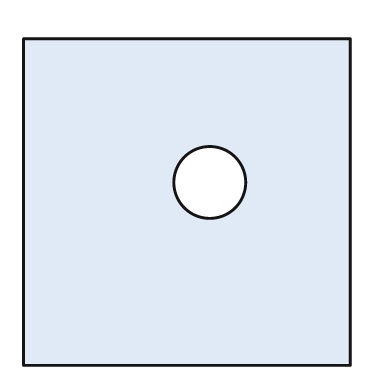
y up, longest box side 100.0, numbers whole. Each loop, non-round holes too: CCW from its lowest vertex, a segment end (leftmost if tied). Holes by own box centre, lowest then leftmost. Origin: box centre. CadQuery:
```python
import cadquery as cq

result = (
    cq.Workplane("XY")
    .moveTo(-50.0, -50.0)
    .lineTo(50.0, -50.0)
    .lineTo(50.0, 50.0)
    .lineTo(-50.0, 50.0)
    .close()
    .moveTo(7.0, 6.0)
    .circle(11.0)
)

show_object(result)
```